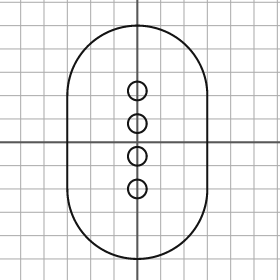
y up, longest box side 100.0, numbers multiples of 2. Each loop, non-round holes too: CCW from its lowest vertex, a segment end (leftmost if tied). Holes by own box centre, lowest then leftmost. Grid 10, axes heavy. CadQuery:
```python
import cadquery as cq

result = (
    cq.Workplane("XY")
    .moveTo(-30.0, -20.0)
    .threePointArc((0.0, -50.0), (30.0, -20.0))
    .lineTo(30.0, 20.0)
    .threePointArc((0.0, 50.0), (-30.0, 20.0))
    .close()
    .moveTo(0.0, -20.0)
    .circle(4.0)
    .moveTo(0.0, -6.0)
    .circle(4.0)
    .moveTo(0.0, 8.0)
    .circle(4.0)
    .moveTo(0.0, 22.0)
    .circle(4.0)
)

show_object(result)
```